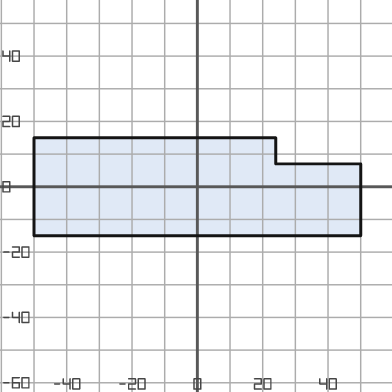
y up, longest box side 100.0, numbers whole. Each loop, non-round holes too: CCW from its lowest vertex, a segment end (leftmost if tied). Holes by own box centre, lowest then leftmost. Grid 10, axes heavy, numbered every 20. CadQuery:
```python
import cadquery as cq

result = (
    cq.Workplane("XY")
    .moveTo(-50.0, -15.0)
    .lineTo(50.0, -15.0)
    .lineTo(50.0, 7.0)
    .lineTo(24.0, 7.0)
    .lineTo(24.0, 15.0)
    .lineTo(-50.0, 15.0)
    .close()
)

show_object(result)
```